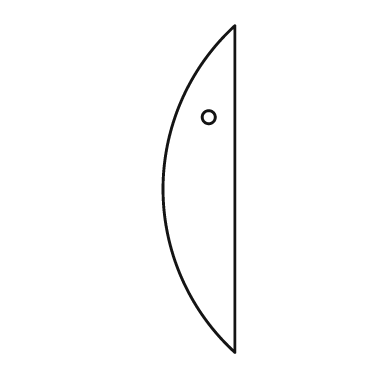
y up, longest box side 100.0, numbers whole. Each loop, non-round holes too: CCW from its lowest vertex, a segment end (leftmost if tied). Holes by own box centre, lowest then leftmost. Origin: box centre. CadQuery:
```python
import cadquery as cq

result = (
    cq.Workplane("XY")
    .moveTo(11.0, -50.0)
    .lineTo(11.0, 50.0)
    .threePointArc((-11.0, 0.0), (11.0, -50.0))
    .close()
    .moveTo(3.0, 22.0)
    .circle(2.0)
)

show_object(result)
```